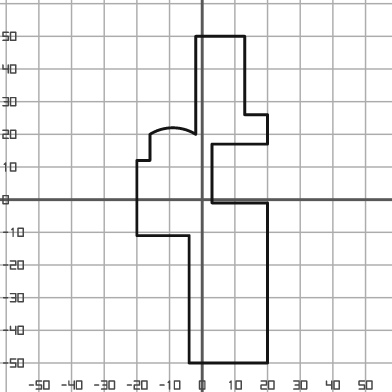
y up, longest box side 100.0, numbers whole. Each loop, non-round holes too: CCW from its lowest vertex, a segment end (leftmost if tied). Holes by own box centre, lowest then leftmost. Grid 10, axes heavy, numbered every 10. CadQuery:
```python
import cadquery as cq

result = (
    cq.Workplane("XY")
    .moveTo(-4.0, -50.0)
    .lineTo(20.0, -50.0)
    .lineTo(20.0, -1.0)
    .lineTo(3.0, -1.0)
    .lineTo(3.0, 17.0)
    .lineTo(20.0, 17.0)
    .lineTo(20.0, 26.0)
    .lineTo(13.0, 26.0)
    .lineTo(13.0, 50.0)
    .lineTo(-2.0, 50.0)
    .lineTo(-2.0, 20.0)
    .threePointArc((-9.0, 22.0), (-16.0, 20.0))
    .lineTo(-16.0, 12.0)
    .lineTo(-20.0, 12.0)
    .lineTo(-20.0, -11.0)
    .lineTo(-4.0, -11.0)
    .close()
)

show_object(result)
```